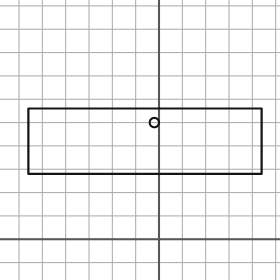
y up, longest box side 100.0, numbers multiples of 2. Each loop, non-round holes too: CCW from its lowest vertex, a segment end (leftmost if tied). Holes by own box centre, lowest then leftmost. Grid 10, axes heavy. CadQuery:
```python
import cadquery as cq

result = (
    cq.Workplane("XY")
    .moveTo(-56.0, 28.0)
    .lineTo(44.0, 28.0)
    .lineTo(44.0, 56.0)
    .lineTo(-56.0, 56.0)
    .close()
    .moveTo(-2.0, 50.0)
    .circle(2.0)
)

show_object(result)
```